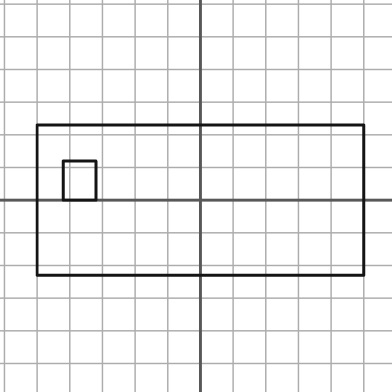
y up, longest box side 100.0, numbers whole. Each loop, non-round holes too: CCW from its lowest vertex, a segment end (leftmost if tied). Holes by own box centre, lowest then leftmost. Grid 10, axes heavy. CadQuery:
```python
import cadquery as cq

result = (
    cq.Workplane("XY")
    .moveTo(-50.0, -23.0)
    .lineTo(50.0, -23.0)
    .lineTo(50.0, 23.0)
    .lineTo(-50.0, 23.0)
    .close()
    .moveTo(-42.0, 0.0)
    .lineTo(-32.0, 0.0)
    .lineTo(-32.0, 12.0)
    .lineTo(-42.0, 12.0)
    .close()
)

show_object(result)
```